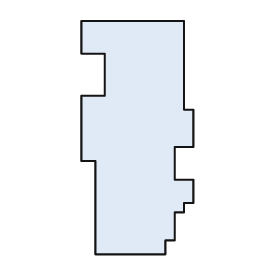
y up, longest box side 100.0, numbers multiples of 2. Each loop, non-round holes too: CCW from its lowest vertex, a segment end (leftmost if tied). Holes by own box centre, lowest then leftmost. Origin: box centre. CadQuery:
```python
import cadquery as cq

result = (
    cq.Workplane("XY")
    .moveTo(-18.0, -50.0)
    .lineTo(12.0, -50.0)
    .lineTo(12.0, -44.0)
    .lineTo(16.0, -44.0)
    .lineTo(16.0, -32.0)
    .lineTo(20.0, -32.0)
    .lineTo(20.0, -28.0)
    .lineTo(24.0, -28.0)
    .lineTo(24.0, -18.0)
    .lineTo(16.0, -18.0)
    .lineTo(16.0, -4.0)
    .lineTo(24.0, -4.0)
    .lineTo(24.0, 12.0)
    .lineTo(20.0, 12.0)
    .lineTo(20.0, 50.0)
    .lineTo(-24.0, 50.0)
    .lineTo(-24.0, 36.0)
    .lineTo(-14.0, 36.0)
    .lineTo(-14.0, 18.0)
    .lineTo(-24.0, 18.0)
    .lineTo(-24.0, -10.0)
    .lineTo(-18.0, -10.0)
    .close()
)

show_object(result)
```